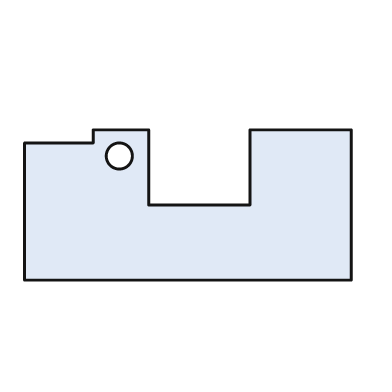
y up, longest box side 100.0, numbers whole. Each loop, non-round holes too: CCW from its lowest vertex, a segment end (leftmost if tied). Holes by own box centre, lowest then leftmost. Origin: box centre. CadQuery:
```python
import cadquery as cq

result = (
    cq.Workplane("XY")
    .moveTo(-50.0, -23.0)
    .lineTo(50.0, -23.0)
    .lineTo(50.0, 23.0)
    .lineTo(19.0, 23.0)
    .lineTo(19.0, 0.0)
    .lineTo(-12.0, 0.0)
    .lineTo(-12.0, 23.0)
    .lineTo(-29.0, 23.0)
    .lineTo(-29.0, 19.0)
    .lineTo(-50.0, 19.0)
    .close()
    .moveTo(-21.0, 15.0)
    .circle(4.0)
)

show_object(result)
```